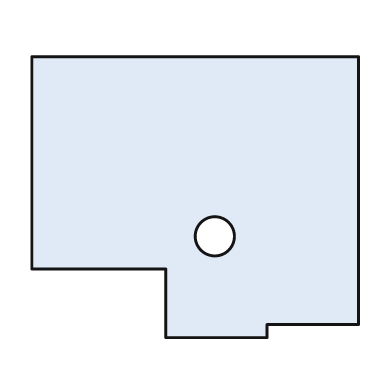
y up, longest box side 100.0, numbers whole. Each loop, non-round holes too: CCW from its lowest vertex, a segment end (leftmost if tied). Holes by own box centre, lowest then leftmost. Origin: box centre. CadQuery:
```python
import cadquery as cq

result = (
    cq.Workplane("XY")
    .moveTo(-9.0, -43.0)
    .lineTo(22.0, -43.0)
    .lineTo(22.0, -39.0)
    .lineTo(50.0, -39.0)
    .lineTo(50.0, 43.0)
    .lineTo(-50.0, 43.0)
    .lineTo(-50.0, -22.0)
    .lineTo(-9.0, -22.0)
    .close()
    .moveTo(6.0, -12.0)
    .circle(6.0)
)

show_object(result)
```